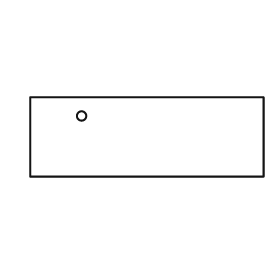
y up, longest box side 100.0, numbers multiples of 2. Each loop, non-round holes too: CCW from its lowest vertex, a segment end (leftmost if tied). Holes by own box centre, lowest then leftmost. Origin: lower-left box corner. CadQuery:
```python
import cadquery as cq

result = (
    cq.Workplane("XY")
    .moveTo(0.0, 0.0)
    .lineTo(100.0, 0.0)
    .lineTo(100.0, 34.0)
    .lineTo(0.0, 34.0)
    .close()
    .moveTo(22.0, 26.0)
    .circle(2.0)
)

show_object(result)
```